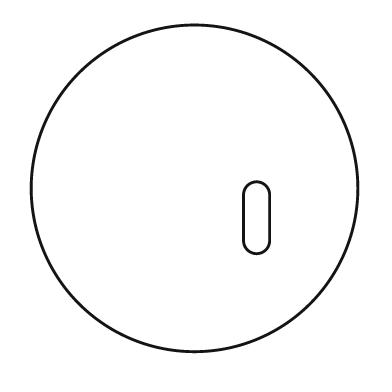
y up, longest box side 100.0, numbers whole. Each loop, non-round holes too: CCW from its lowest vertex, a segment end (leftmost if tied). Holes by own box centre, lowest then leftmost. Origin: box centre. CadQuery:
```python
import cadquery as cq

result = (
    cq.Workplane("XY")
    .moveTo(0.0, 0.0)
    .circle(50.0)
    .moveTo(15.0, -16.0)
    .threePointArc((19.0, -20.0), (23.0, -16.0))
    .lineTo(23.0, -2.0)
    .threePointArc((19.0, 2.0), (15.0, -2.0))
    .close()
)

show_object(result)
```